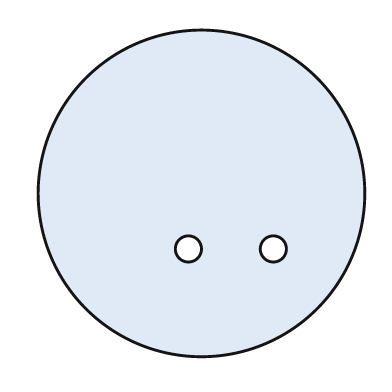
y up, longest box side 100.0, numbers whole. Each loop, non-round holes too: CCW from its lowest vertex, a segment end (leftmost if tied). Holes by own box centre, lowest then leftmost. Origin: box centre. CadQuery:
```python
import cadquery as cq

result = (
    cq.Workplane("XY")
    .moveTo(0.0, 0.0)
    .circle(50.0)
    .moveTo(-4.0, -17.0)
    .circle(4.0)
    .moveTo(22.0, -17.0)
    .circle(4.0)
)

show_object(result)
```